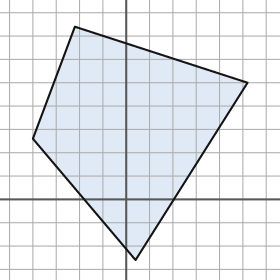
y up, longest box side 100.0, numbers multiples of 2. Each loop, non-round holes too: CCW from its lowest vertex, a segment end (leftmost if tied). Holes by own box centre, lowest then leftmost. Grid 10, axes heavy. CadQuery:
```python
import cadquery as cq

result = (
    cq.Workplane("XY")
    .moveTo(4.0, -26.0)
    .lineTo(52.0, 50.0)
    .lineTo(-22.0, 74.0)
    .lineTo(-40.0, 26.0)
    .close()
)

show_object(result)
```